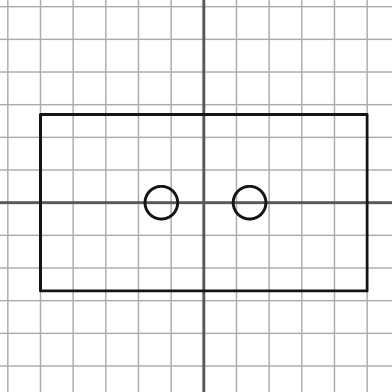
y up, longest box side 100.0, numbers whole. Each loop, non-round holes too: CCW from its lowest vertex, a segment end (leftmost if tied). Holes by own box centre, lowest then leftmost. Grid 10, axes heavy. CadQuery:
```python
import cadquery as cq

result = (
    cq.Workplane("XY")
    .moveTo(-50.0, -27.0)
    .lineTo(50.0, -27.0)
    .lineTo(50.0, 27.0)
    .lineTo(-50.0, 27.0)
    .close()
    .moveTo(-13.0, 0.0)
    .circle(5.0)
    .moveTo(14.0, 0.0)
    .circle(5.0)
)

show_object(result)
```